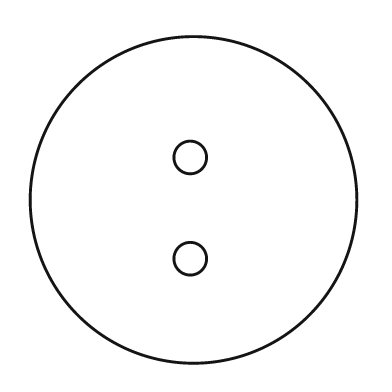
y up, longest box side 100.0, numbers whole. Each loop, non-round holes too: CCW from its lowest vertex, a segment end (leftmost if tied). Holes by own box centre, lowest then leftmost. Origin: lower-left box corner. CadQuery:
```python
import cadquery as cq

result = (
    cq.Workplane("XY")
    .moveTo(50.0, 50.0)
    .circle(50.0)
    .moveTo(49.0, 32.0)
    .circle(5.0)
    .moveTo(49.0, 63.0)
    .circle(5.0)
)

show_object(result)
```